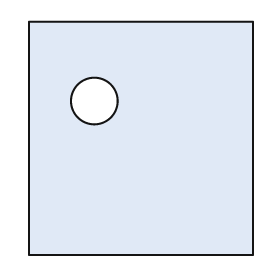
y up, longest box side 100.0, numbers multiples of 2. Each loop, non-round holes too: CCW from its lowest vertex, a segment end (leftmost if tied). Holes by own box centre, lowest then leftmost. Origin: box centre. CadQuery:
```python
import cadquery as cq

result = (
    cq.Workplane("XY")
    .moveTo(-48.0, -50.0)
    .lineTo(48.0, -50.0)
    .lineTo(48.0, 50.0)
    .lineTo(-48.0, 50.0)
    .close()
    .moveTo(-20.0, 16.0)
    .circle(10.0)
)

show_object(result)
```